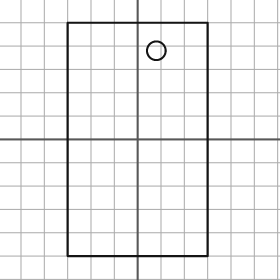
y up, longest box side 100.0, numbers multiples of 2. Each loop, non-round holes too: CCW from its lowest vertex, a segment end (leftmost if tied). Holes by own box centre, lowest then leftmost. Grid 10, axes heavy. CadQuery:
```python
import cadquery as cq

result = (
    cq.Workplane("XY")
    .moveTo(-30.0, -50.0)
    .lineTo(30.0, -50.0)
    .lineTo(30.0, 50.0)
    .lineTo(-30.0, 50.0)
    .close()
    .moveTo(8.0, 38.0)
    .circle(4.0)
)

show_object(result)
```